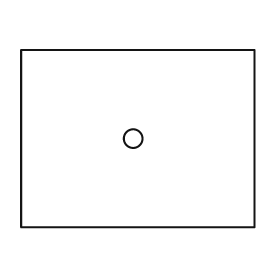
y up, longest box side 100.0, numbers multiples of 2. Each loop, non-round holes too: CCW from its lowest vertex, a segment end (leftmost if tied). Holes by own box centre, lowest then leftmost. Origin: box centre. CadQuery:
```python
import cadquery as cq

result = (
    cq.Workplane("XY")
    .moveTo(-50.0, -38.0)
    .lineTo(50.0, -38.0)
    .lineTo(50.0, 38.0)
    .lineTo(-50.0, 38.0)
    .close()
    .moveTo(-2.0, 0.0)
    .circle(4.0)
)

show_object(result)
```